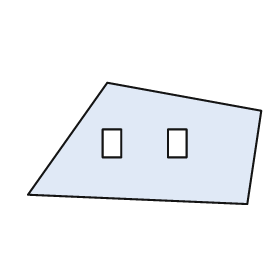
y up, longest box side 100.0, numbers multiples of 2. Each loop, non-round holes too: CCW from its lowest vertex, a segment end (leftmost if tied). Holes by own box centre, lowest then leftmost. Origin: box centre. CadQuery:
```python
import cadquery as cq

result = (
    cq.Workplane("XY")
    .moveTo(44.0, -26.0)
    .lineTo(50.0, 14.0)
    .lineTo(-16.0, 26.0)
    .lineTo(-50.0, -22.0)
    .close()
    .moveTo(-18.0, -6.0)
    .lineTo(-10.0, -6.0)
    .lineTo(-10.0, 6.0)
    .lineTo(-18.0, 6.0)
    .close()
    .moveTo(10.0, -6.0)
    .lineTo(18.0, -6.0)
    .lineTo(18.0, 6.0)
    .lineTo(10.0, 6.0)
    .close()
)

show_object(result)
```